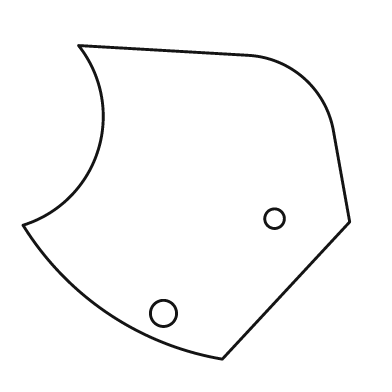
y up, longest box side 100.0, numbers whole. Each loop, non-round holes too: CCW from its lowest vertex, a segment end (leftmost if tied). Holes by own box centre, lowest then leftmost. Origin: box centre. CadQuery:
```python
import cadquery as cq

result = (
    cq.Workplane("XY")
    .moveTo(11.0, -48.0)
    .lineTo(50.0, -6.0)
    .lineTo(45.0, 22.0)
    .threePointArc((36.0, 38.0), (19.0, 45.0))
    .lineTo(-33.0, 48.0)
    .threePointArc((-27.0, 16.0), (-50.0, -7.0))
    .threePointArc((-24.0, -34.0), (11.0, -48.0))
    .close()
    .moveTo(-7.0, -34.0)
    .circle(4.0)
    .moveTo(27.0, -5.0)
    .circle(3.0)
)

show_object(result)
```